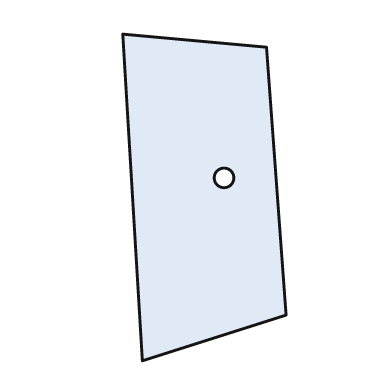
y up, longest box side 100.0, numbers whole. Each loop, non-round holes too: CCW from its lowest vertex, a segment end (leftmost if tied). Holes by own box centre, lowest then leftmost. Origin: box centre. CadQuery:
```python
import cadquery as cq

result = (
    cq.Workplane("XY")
    .moveTo(-19.0, -50.0)
    .lineTo(25.0, -36.0)
    .lineTo(19.0, 46.0)
    .lineTo(-25.0, 50.0)
    .close()
    .moveTo(6.0, 6.0)
    .circle(3.0)
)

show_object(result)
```